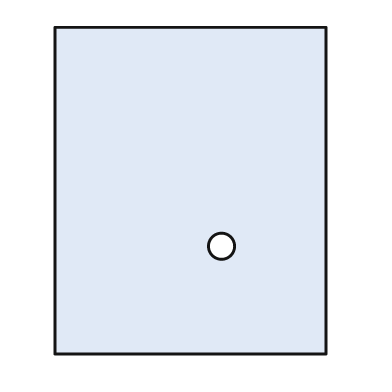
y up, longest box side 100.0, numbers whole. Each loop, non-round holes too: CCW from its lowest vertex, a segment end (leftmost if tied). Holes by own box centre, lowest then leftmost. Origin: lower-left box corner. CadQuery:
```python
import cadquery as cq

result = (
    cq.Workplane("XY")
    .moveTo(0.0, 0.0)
    .lineTo(83.0, 0.0)
    .lineTo(83.0, 100.0)
    .lineTo(0.0, 100.0)
    .close()
    .moveTo(51.0, 33.0)
    .circle(4.0)
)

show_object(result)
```